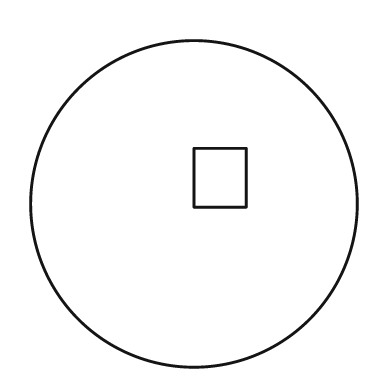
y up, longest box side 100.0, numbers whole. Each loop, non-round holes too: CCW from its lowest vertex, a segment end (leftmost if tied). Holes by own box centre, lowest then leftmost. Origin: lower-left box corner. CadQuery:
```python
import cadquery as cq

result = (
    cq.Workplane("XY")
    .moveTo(50.0, 50.0)
    .circle(50.0)
    .moveTo(50.0, 49.0)
    .lineTo(66.0, 49.0)
    .lineTo(66.0, 67.0)
    .lineTo(50.0, 67.0)
    .close()
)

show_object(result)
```